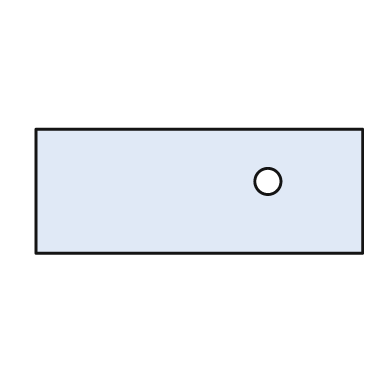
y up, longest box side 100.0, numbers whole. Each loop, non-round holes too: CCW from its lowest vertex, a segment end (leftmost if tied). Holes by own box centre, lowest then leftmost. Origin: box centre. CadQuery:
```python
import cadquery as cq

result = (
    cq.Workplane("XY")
    .moveTo(-50.0, -19.0)
    .lineTo(50.0, -19.0)
    .lineTo(50.0, 19.0)
    .lineTo(-50.0, 19.0)
    .close()
    .moveTo(21.0, 3.0)
    .circle(4.0)
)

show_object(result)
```